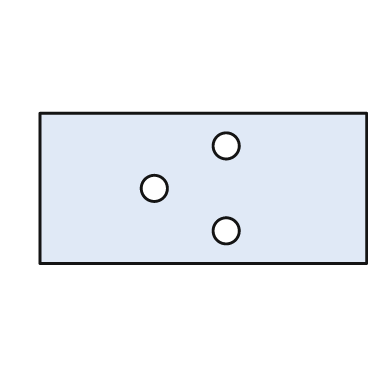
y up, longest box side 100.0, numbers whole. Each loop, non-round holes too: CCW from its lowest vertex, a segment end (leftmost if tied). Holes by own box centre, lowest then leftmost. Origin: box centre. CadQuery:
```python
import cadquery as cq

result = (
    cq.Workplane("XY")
    .moveTo(-50.0, -23.0)
    .lineTo(50.0, -23.0)
    .lineTo(50.0, 23.0)
    .lineTo(-50.0, 23.0)
    .close()
    .moveTo(7.0, -13.0)
    .circle(4.0)
    .moveTo(-15.0, 0.0)
    .circle(4.0)
    .moveTo(7.0, 13.0)
    .circle(4.0)
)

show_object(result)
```